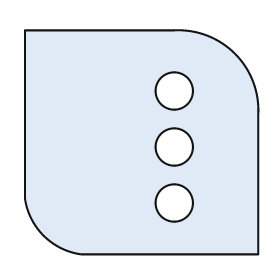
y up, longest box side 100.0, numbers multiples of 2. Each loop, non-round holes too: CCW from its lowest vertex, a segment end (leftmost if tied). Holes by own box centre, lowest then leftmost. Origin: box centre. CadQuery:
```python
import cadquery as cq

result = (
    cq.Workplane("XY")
    .moveTo(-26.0, -48.0)
    .lineTo(50.0, -48.0)
    .lineTo(50.0, 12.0)
    .threePointArc((40.0, 38.0), (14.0, 48.0))
    .lineTo(-50.0, 48.0)
    .lineTo(-50.0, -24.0)
    .threePointArc((-42.0, -40.0), (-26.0, -48.0))
    .close()
    .moveTo(14.0, -26.0)
    .circle(8.0)
    .moveTo(14.0, -2.0)
    .circle(8.0)
    .moveTo(14.0, 22.0)
    .circle(8.0)
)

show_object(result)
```